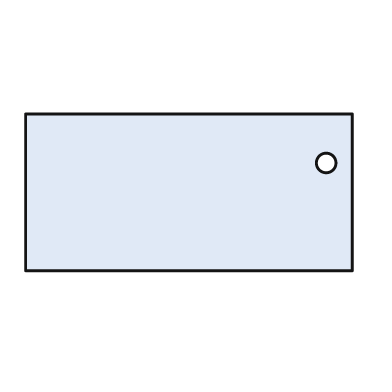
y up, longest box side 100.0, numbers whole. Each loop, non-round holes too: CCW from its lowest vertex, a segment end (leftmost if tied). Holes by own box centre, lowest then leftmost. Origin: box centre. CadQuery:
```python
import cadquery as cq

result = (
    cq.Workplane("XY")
    .moveTo(-50.0, -24.0)
    .lineTo(50.0, -24.0)
    .lineTo(50.0, 24.0)
    .lineTo(-50.0, 24.0)
    .close()
    .moveTo(42.0, 9.0)
    .circle(3.0)
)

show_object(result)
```